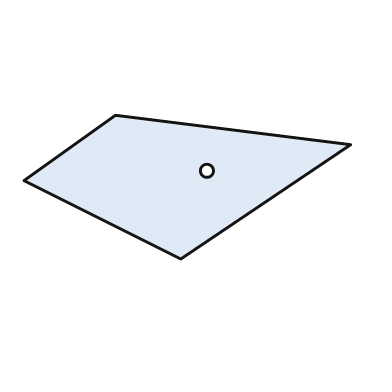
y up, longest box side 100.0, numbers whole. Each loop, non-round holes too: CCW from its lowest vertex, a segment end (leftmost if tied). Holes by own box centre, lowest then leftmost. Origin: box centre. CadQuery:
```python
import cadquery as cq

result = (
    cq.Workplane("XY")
    .moveTo(-2.0, -22.0)
    .lineTo(50.0, 13.0)
    .lineTo(-22.0, 22.0)
    .lineTo(-50.0, 2.0)
    .close()
    .moveTo(6.0, 5.0)
    .circle(2.0)
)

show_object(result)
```